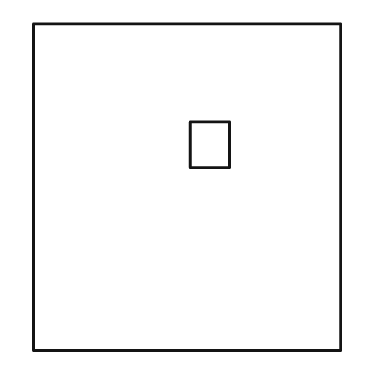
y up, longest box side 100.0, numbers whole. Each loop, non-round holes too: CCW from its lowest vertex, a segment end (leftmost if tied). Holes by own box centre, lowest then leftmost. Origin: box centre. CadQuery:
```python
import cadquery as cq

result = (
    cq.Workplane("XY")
    .moveTo(-47.0, -50.0)
    .lineTo(47.0, -50.0)
    .lineTo(47.0, 50.0)
    .lineTo(-47.0, 50.0)
    .close()
    .moveTo(1.0, 6.0)
    .lineTo(13.0, 6.0)
    .lineTo(13.0, 20.0)
    .lineTo(1.0, 20.0)
    .close()
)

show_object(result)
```